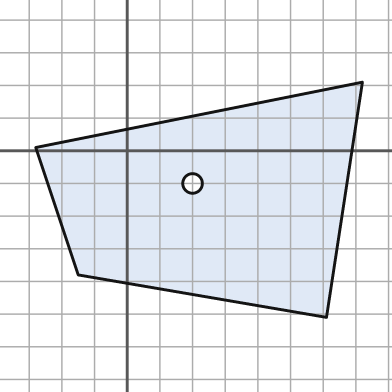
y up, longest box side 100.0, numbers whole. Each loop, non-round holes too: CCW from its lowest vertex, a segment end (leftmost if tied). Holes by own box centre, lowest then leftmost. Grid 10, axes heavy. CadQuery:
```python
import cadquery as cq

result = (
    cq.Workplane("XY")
    .moveTo(61.0, -51.0)
    .lineTo(72.0, 21.0)
    .lineTo(-28.0, 1.0)
    .lineTo(-15.0, -38.0)
    .close()
    .moveTo(20.0, -10.0)
    .circle(3.0)
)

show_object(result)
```